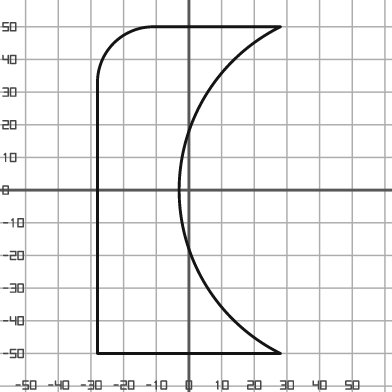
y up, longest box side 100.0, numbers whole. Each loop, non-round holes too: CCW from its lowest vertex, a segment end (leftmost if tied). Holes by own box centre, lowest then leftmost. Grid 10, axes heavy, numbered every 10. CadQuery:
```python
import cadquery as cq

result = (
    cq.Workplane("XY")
    .moveTo(-28.0, -50.0)
    .lineTo(28.0, -50.0)
    .threePointArc((-3.0, 0.0), (28.0, 50.0))
    .lineTo(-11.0, 50.0)
    .threePointArc((-23.0, 45.0), (-28.0, 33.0))
    .close()
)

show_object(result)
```